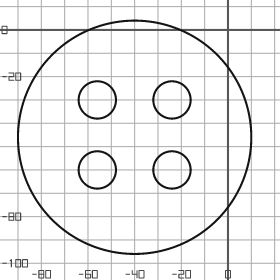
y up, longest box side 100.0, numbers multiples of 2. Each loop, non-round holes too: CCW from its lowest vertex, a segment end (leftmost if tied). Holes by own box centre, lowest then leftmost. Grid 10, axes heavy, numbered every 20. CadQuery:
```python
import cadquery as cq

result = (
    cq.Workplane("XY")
    .moveTo(-40.0, -46.0)
    .circle(50.0)
    .moveTo(-56.0, -60.0)
    .circle(8.0)
    .moveTo(-24.0, -60.0)
    .circle(8.0)
    .moveTo(-56.0, -30.0)
    .circle(8.0)
    .moveTo(-24.0, -30.0)
    .circle(8.0)
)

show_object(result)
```